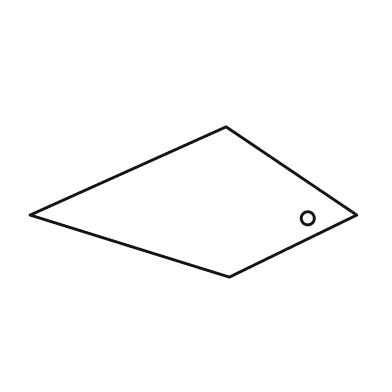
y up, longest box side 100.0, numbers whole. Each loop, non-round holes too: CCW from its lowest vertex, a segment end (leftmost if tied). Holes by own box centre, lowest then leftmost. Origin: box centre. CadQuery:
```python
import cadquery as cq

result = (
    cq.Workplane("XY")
    .moveTo(11.0, -23.0)
    .lineTo(50.0, -4.0)
    .lineTo(10.0, 23.0)
    .lineTo(-50.0, -4.0)
    .close()
    .moveTo(35.0, -5.0)
    .circle(2.0)
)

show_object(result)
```